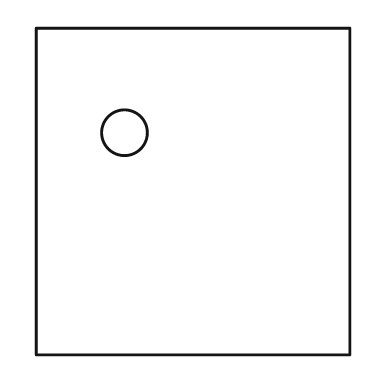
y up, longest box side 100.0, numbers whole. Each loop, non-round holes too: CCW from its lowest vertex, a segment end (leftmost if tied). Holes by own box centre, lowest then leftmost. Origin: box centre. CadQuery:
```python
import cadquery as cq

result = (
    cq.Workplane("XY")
    .moveTo(-48.0, -50.0)
    .lineTo(48.0, -50.0)
    .lineTo(48.0, 50.0)
    .lineTo(-48.0, 50.0)
    .close()
    .moveTo(-21.0, 18.0)
    .circle(7.0)
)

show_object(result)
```